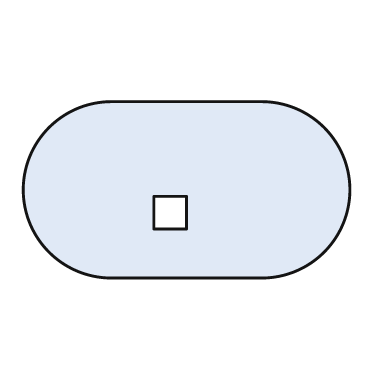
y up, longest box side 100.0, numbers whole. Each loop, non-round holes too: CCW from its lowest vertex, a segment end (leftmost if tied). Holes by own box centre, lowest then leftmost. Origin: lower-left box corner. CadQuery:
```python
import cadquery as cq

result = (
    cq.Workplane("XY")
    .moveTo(27.0, 0.0)
    .lineTo(73.0, 0.0)
    .threePointArc((100.0, 27.0), (73.0, 54.0))
    .lineTo(27.0, 54.0)
    .threePointArc((0.0, 27.0), (27.0, 0.0))
    .close()
    .moveTo(40.0, 15.0)
    .lineTo(50.0, 15.0)
    .lineTo(50.0, 25.0)
    .lineTo(40.0, 25.0)
    .close()
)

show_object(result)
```